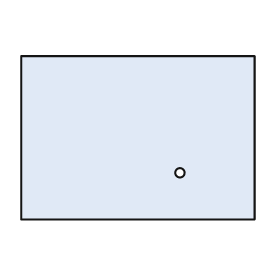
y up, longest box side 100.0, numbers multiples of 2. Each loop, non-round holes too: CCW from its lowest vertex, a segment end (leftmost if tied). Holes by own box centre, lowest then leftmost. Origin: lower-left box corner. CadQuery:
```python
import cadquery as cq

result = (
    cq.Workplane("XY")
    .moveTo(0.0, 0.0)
    .lineTo(100.0, 0.0)
    .lineTo(100.0, 70.0)
    .lineTo(0.0, 70.0)
    .close()
    .moveTo(68.0, 20.0)
    .circle(2.0)
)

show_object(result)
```